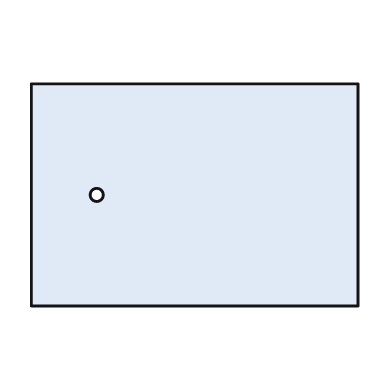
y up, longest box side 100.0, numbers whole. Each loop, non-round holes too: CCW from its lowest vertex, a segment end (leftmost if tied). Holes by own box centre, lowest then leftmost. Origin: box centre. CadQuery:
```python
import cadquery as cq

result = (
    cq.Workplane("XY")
    .moveTo(-50.0, -34.0)
    .lineTo(50.0, -34.0)
    .lineTo(50.0, 34.0)
    .lineTo(-50.0, 34.0)
    .close()
    .moveTo(-30.0, 0.0)
    .circle(2.0)
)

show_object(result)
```